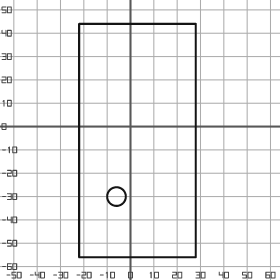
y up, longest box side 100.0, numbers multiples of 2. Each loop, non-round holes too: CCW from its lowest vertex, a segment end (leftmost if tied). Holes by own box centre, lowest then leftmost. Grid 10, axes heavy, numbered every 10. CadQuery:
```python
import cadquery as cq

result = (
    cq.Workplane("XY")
    .moveTo(-22.0, -56.0)
    .lineTo(28.0, -56.0)
    .lineTo(28.0, 44.0)
    .lineTo(-22.0, 44.0)
    .close()
    .moveTo(-6.0, -30.0)
    .circle(4.0)
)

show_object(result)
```